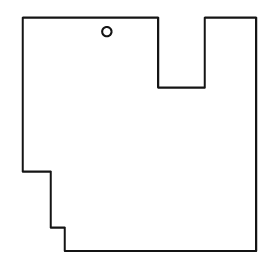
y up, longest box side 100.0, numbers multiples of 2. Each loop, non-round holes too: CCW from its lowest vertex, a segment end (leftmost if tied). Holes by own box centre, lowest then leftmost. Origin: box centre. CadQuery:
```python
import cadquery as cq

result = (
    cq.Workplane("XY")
    .moveTo(-32.0, -50.0)
    .lineTo(50.0, -50.0)
    .lineTo(50.0, 50.0)
    .lineTo(28.0, 50.0)
    .lineTo(28.0, 20.0)
    .lineTo(8.0, 20.0)
    .lineTo(8.0, 50.0)
    .lineTo(-50.0, 50.0)
    .lineTo(-50.0, -16.0)
    .lineTo(-38.0, -16.0)
    .lineTo(-38.0, -40.0)
    .lineTo(-32.0, -40.0)
    .close()
    .moveTo(-14.0, 44.0)
    .circle(2.0)
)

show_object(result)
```